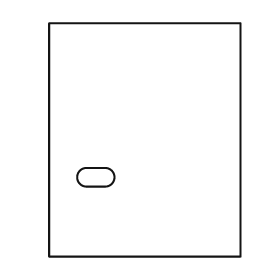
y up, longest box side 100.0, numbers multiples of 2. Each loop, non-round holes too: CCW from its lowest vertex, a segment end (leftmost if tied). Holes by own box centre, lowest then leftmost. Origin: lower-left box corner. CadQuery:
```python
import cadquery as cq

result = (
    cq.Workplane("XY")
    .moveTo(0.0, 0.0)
    .lineTo(82.0, 0.0)
    .lineTo(82.0, 100.0)
    .lineTo(0.0, 100.0)
    .close()
    .moveTo(16.0, 30.0)
    .lineTo(24.0, 30.0)
    .threePointArc((28.0, 34.0), (24.0, 38.0))
    .lineTo(16.0, 38.0)
    .threePointArc((12.0, 34.0), (16.0, 30.0))
    .close()
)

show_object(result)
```